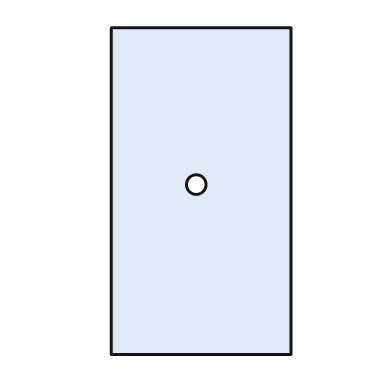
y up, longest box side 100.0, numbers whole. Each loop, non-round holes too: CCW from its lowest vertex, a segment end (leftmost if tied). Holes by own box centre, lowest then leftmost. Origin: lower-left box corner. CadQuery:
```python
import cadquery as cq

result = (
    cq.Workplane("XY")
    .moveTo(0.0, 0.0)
    .lineTo(55.0, 0.0)
    .lineTo(55.0, 100.0)
    .lineTo(0.0, 100.0)
    .close()
    .moveTo(26.0, 52.0)
    .circle(3.0)
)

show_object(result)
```